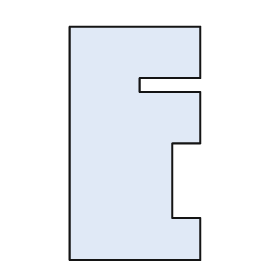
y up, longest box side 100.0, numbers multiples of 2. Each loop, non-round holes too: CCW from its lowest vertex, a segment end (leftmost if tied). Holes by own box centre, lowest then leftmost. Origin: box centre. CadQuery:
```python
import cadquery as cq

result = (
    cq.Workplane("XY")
    .moveTo(-28.0, -50.0)
    .lineTo(28.0, -50.0)
    .lineTo(28.0, -32.0)
    .lineTo(16.0, -32.0)
    .lineTo(16.0, 0.0)
    .lineTo(28.0, 0.0)
    .lineTo(28.0, 22.0)
    .lineTo(2.0, 22.0)
    .lineTo(2.0, 28.0)
    .lineTo(28.0, 28.0)
    .lineTo(28.0, 50.0)
    .lineTo(-28.0, 50.0)
    .close()
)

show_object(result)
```